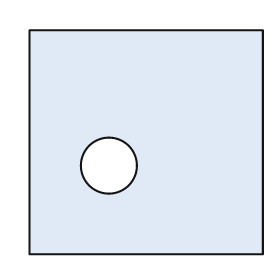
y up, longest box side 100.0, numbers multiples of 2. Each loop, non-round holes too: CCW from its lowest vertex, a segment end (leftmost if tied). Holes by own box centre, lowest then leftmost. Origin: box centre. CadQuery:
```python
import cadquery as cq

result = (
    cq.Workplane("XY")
    .moveTo(-50.0, -48.0)
    .lineTo(50.0, -48.0)
    .lineTo(50.0, 48.0)
    .lineTo(-50.0, 48.0)
    .close()
    .moveTo(-16.0, -10.0)
    .circle(12.0)
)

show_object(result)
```